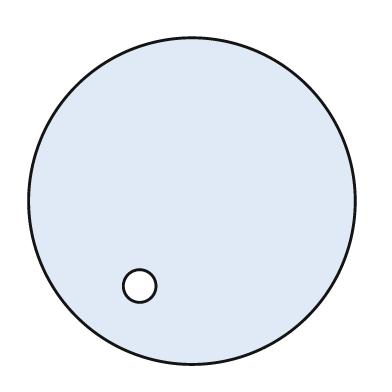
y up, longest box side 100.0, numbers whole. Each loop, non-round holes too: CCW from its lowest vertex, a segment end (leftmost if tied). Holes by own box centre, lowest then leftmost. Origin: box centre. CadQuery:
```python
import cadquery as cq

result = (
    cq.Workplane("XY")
    .moveTo(0.0, 0.0)
    .circle(50.0)
    .moveTo(-16.0, -26.0)
    .circle(5.0)
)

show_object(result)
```